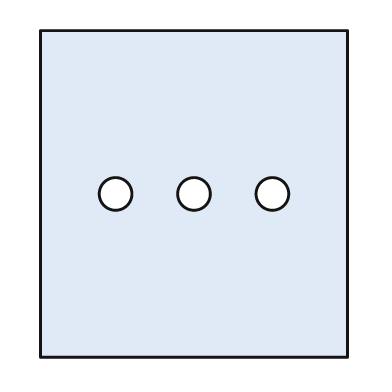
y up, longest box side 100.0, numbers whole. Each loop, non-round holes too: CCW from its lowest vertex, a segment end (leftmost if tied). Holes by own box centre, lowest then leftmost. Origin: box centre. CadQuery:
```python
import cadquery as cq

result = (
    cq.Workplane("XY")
    .moveTo(-47.0, -50.0)
    .lineTo(47.0, -50.0)
    .lineTo(47.0, 50.0)
    .lineTo(-47.0, 50.0)
    .close()
    .moveTo(-24.0, 0.0)
    .circle(5.0)
    .moveTo(0.0, 0.0)
    .circle(5.0)
    .moveTo(24.0, 0.0)
    .circle(5.0)
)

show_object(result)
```